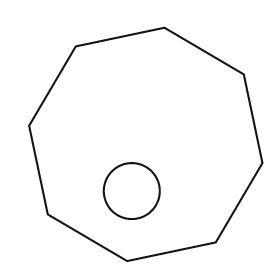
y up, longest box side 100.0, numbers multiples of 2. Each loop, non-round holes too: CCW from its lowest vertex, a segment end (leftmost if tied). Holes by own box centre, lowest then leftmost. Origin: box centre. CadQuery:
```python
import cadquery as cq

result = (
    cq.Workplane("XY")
    .moveTo(-8.0, -50.0)
    .lineTo(30.0, -42.0)
    .lineTo(50.0, -8.0)
    .lineTo(42.0, 30.0)
    .lineTo(8.0, 50.0)
    .lineTo(-30.0, 42.0)
    .lineTo(-50.0, 8.0)
    .lineTo(-42.0, -30.0)
    .close()
    .moveTo(-6.0, -20.0)
    .circle(12.0)
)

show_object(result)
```